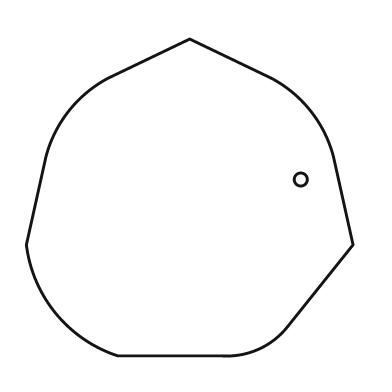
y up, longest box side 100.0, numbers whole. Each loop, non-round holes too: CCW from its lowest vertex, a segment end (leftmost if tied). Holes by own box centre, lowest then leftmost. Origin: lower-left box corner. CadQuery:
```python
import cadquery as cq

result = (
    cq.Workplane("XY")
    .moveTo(28.0, 0.0)
    .lineTo(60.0, 0.0)
    .threePointArc((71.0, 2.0), (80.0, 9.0))
    .lineTo(100.0, 34.0)
    .lineTo(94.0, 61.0)
    .threePointArc((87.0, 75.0), (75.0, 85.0))
    .lineTo(50.0, 97.0)
    .lineTo(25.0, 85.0)
    .threePointArc((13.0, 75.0), (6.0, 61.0))
    .lineTo(0.0, 34.0)
    .threePointArc((9.0, 13.0), (28.0, 0.0))
    .close()
    .moveTo(84.0, 54.0)
    .circle(2.0)
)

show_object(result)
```